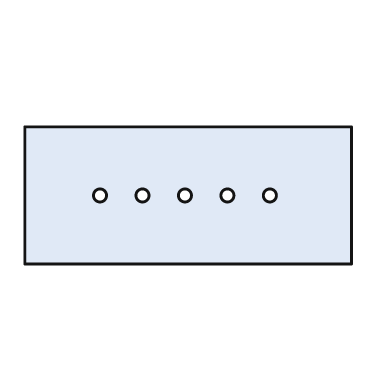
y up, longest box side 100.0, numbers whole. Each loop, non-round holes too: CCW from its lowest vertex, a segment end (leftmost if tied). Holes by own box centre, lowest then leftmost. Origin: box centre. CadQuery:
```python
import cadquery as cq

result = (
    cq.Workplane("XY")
    .moveTo(-50.0, -21.0)
    .lineTo(50.0, -21.0)
    .lineTo(50.0, 21.0)
    .lineTo(-50.0, 21.0)
    .close()
    .moveTo(-27.0, 0.0)
    .circle(2.0)
    .moveTo(-14.0, 0.0)
    .circle(2.0)
    .moveTo(-1.0, 0.0)
    .circle(2.0)
    .moveTo(12.0, 0.0)
    .circle(2.0)
    .moveTo(25.0, 0.0)
    .circle(2.0)
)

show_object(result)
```